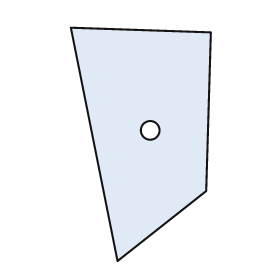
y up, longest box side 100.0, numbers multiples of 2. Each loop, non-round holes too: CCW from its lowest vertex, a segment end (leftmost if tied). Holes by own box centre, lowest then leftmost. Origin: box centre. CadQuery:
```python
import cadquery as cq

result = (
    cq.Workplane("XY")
    .moveTo(-10.0, -50.0)
    .lineTo(28.0, -20.0)
    .lineTo(30.0, 48.0)
    .lineTo(-30.0, 50.0)
    .close()
    .moveTo(4.0, 6.0)
    .circle(4.0)
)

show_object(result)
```